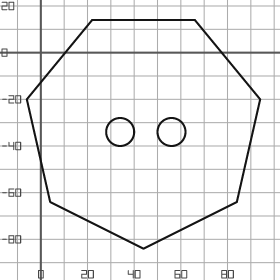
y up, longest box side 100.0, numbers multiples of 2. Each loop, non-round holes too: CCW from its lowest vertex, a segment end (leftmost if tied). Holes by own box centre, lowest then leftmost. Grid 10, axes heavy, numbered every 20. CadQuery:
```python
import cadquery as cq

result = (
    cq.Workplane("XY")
    .moveTo(44.0, -84.0)
    .lineTo(84.0, -64.0)
    .lineTo(94.0, -20.0)
    .lineTo(66.0, 14.0)
    .lineTo(22.0, 14.0)
    .lineTo(-6.0, -20.0)
    .lineTo(4.0, -64.0)
    .close()
    .moveTo(34.0, -34.0)
    .circle(6.0)
    .moveTo(56.0, -34.0)
    .circle(6.0)
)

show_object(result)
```